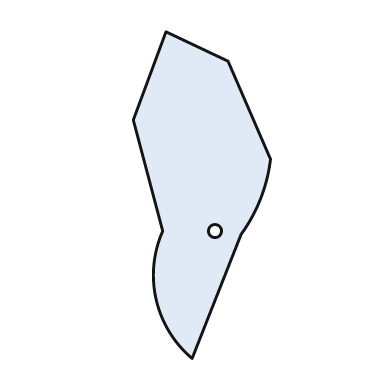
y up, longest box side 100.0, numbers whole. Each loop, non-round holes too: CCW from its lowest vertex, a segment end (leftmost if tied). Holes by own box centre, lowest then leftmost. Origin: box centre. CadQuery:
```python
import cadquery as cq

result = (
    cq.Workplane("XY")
    .moveTo(-3.0, -50.0)
    .lineTo(12.0, -12.0)
    .threePointArc((18.0, -1.0), (21.0, 11.0))
    .lineTo(8.0, 41.0)
    .lineTo(-11.0, 50.0)
    .lineTo(-21.0, 23.0)
    .lineTo(-12.0, -11.0)
    .threePointArc((-14.0, -32.0), (-3.0, -50.0))
    .close()
    .moveTo(4.0, -11.0)
    .circle(2.0)
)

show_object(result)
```